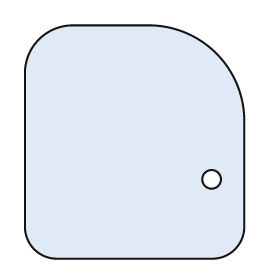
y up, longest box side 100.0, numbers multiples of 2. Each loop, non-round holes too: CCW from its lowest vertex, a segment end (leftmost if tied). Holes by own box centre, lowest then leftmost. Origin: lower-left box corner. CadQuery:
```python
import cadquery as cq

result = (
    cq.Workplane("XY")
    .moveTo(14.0, 0.0)
    .lineTo(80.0, 0.0)
    .threePointArc((90.0, 4.0), (94.0, 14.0))
    .lineTo(94.0, 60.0)
    .threePointArc((82.0, 88.0), (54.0, 100.0))
    .lineTo(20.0, 100.0)
    .threePointArc((6.0, 94.0), (0.0, 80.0))
    .lineTo(0.0, 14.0)
    .threePointArc((4.0, 4.0), (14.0, 0.0))
    .close()
    .moveTo(80.0, 34.0)
    .circle(4.0)
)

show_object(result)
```